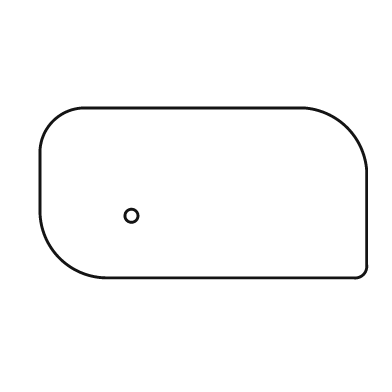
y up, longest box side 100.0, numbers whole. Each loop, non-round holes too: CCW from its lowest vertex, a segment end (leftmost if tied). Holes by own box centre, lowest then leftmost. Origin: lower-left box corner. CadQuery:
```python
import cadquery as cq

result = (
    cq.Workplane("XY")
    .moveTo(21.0, 0.0)
    .lineTo(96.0, 0.0)
    .threePointArc((99.0, 1.0), (100.0, 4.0))
    .lineTo(100.0, 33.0)
    .threePointArc((94.0, 46.0), (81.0, 52.0))
    .lineTo(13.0, 52.0)
    .threePointArc((4.0, 48.0), (0.0, 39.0))
    .lineTo(0.0, 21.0)
    .threePointArc((6.0, 6.0), (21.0, 0.0))
    .close()
    .moveTo(28.0, 19.0)
    .circle(2.0)
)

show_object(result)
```